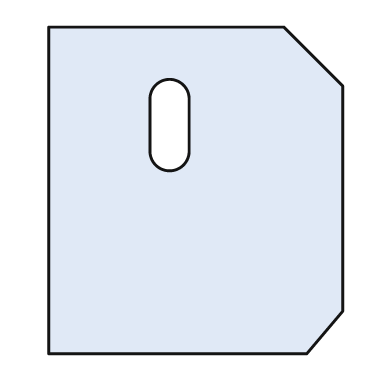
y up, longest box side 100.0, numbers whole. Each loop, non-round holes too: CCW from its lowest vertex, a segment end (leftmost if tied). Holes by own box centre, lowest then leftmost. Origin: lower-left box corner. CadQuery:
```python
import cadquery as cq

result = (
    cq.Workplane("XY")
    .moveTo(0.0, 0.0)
    .lineTo(79.0, 0.0)
    .lineTo(90.0, 13.0)
    .lineTo(90.0, 82.0)
    .lineTo(72.0, 100.0)
    .lineTo(0.0, 100.0)
    .close()
    .moveTo(31.0, 62.0)
    .threePointArc((37.0, 56.0), (43.0, 62.0))
    .lineTo(43.0, 78.0)
    .threePointArc((37.0, 84.0), (31.0, 78.0))
    .close()
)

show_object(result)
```